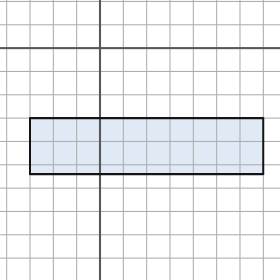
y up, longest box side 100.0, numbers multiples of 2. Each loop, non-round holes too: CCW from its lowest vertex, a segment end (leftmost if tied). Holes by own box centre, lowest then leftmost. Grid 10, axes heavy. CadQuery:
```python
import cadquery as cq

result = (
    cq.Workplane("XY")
    .moveTo(-30.0, -54.0)
    .lineTo(70.0, -54.0)
    .lineTo(70.0, -30.0)
    .lineTo(-30.0, -30.0)
    .close()
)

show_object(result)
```